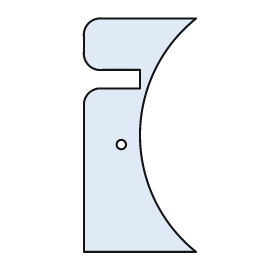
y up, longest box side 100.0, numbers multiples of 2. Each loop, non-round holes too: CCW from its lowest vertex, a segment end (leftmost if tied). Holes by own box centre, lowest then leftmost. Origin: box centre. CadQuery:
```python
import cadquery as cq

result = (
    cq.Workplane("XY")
    .moveTo(-24.0, -50.0)
    .lineTo(24.0, -50.0)
    .threePointArc((0.0, 0.0), (24.0, 50.0))
    .lineTo(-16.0, 50.0)
    .threePointArc((-22.0, 48.0), (-24.0, 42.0))
    .lineTo(-24.0, 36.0)
    .threePointArc((-22.0, 30.0), (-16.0, 28.0))
    .lineTo(0.0, 28.0)
    .lineTo(0.0, 20.0)
    .lineTo(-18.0, 20.0)
    .threePointArc((-22.0, 18.0), (-24.0, 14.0))
    .close()
    .moveTo(-8.0, -4.0)
    .circle(2.0)
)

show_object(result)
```